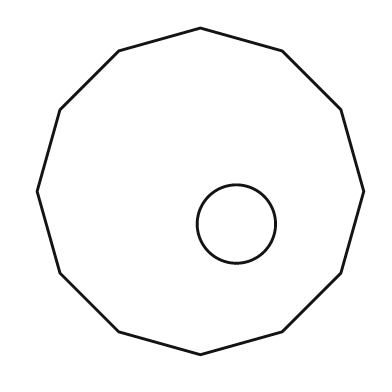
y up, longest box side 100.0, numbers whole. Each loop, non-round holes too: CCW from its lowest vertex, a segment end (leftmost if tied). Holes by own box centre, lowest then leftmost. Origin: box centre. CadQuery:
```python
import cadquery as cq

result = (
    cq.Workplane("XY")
    .moveTo(0.0, -50.0)
    .lineTo(25.0, -43.0)
    .lineTo(43.0, -25.0)
    .lineTo(50.0, 0.0)
    .lineTo(43.0, 25.0)
    .lineTo(25.0, 43.0)
    .lineTo(0.0, 50.0)
    .lineTo(-25.0, 43.0)
    .lineTo(-43.0, 25.0)
    .lineTo(-50.0, 0.0)
    .lineTo(-43.0, -25.0)
    .lineTo(-25.0, -43.0)
    .close()
    .moveTo(11.0, -10.0)
    .circle(12.0)
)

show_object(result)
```